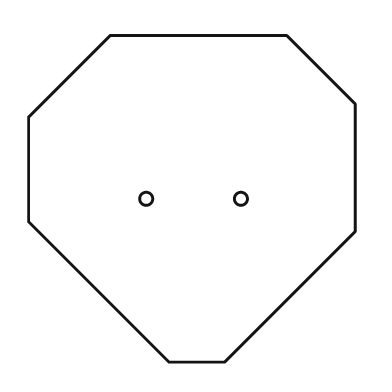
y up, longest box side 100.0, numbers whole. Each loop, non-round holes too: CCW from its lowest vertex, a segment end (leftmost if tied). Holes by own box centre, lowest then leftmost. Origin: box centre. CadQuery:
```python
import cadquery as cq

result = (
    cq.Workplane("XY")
    .moveTo(-7.0, -50.0)
    .lineTo(10.0, -50.0)
    .lineTo(50.0, -10.0)
    .lineTo(50.0, 29.0)
    .lineTo(29.0, 50.0)
    .lineTo(-25.0, 50.0)
    .lineTo(-50.0, 25.0)
    .lineTo(-50.0, -7.0)
    .close()
    .moveTo(-14.0, 0.0)
    .circle(2.0)
    .moveTo(15.0, 0.0)
    .circle(2.0)
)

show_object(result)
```